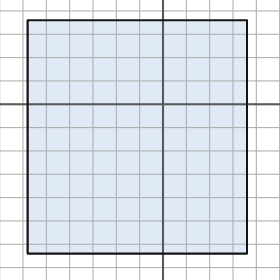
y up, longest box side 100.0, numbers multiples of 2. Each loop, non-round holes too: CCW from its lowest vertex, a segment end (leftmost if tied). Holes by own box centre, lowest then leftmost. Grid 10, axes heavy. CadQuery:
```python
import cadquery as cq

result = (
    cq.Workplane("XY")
    .moveTo(-58.0, -64.0)
    .lineTo(36.0, -64.0)
    .lineTo(36.0, 36.0)
    .lineTo(-58.0, 36.0)
    .close()
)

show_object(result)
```